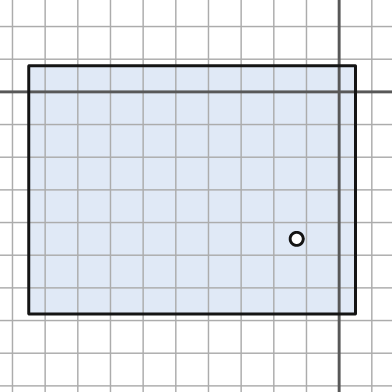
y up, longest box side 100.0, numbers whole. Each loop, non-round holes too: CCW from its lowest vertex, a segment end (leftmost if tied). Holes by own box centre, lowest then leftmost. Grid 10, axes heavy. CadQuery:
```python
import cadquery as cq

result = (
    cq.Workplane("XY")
    .moveTo(-95.0, -68.0)
    .lineTo(5.0, -68.0)
    .lineTo(5.0, 8.0)
    .lineTo(-95.0, 8.0)
    .close()
    .moveTo(-13.0, -45.0)
    .circle(2.0)
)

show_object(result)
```